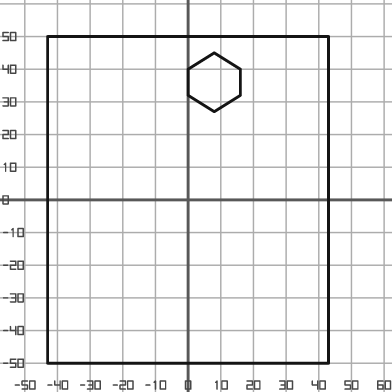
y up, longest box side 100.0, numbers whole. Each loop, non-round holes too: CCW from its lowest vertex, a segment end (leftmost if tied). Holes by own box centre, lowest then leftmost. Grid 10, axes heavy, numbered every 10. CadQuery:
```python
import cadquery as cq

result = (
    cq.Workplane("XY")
    .moveTo(-43.0, -50.0)
    .lineTo(43.0, -50.0)
    .lineTo(43.0, 50.0)
    .lineTo(-43.0, 50.0)
    .close()
    .moveTo(8.0, 27.0)
    .lineTo(16.0, 32.0)
    .lineTo(16.0, 40.0)
    .lineTo(8.0, 45.0)
    .lineTo(0.0, 40.0)
    .lineTo(0.0, 32.0)
    .close()
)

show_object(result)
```